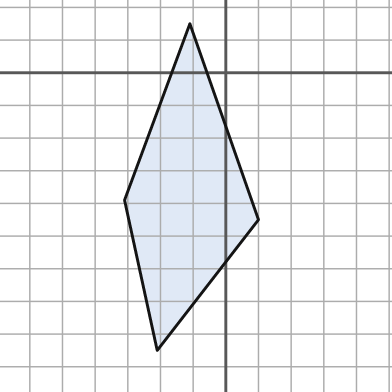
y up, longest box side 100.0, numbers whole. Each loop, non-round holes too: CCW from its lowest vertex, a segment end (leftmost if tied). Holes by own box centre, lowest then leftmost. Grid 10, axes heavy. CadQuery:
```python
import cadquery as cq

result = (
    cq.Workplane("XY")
    .moveTo(-21.0, -85.0)
    .lineTo(10.0, -45.0)
    .lineTo(-11.0, 15.0)
    .lineTo(-31.0, -39.0)
    .close()
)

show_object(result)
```